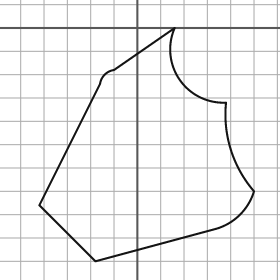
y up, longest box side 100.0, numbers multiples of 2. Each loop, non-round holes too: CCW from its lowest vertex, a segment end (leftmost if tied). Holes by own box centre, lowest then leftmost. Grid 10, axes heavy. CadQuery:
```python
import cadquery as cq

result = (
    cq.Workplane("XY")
    .moveTo(-18.0, -100.0)
    .lineTo(34.0, -86.0)
    .threePointArc((44.0, -80.0), (50.0, -70.0))
    .threePointArc((40.0, -52.0), (38.0, -32.0))
    .threePointArc((18.0, -22.0), (16.0, 0.0))
    .lineTo(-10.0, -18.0)
    .threePointArc((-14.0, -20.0), (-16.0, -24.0))
    .lineTo(-42.0, -76.0)
    .close()
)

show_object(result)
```